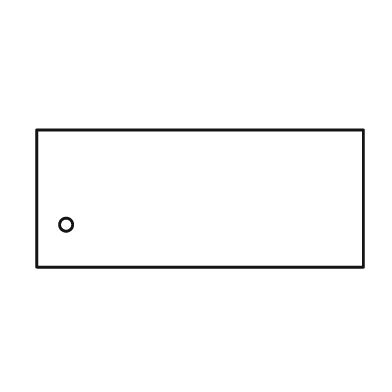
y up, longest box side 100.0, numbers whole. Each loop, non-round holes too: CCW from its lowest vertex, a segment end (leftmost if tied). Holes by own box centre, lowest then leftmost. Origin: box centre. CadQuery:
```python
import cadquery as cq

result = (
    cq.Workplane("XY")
    .moveTo(-50.0, -21.0)
    .lineTo(50.0, -21.0)
    .lineTo(50.0, 21.0)
    .lineTo(-50.0, 21.0)
    .close()
    .moveTo(-41.0, -8.0)
    .circle(2.0)
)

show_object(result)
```